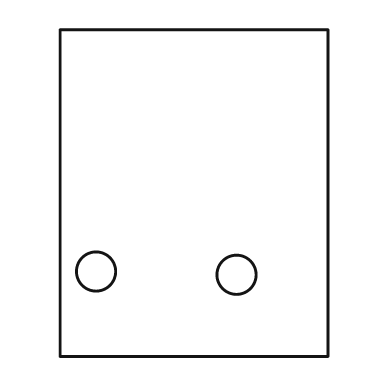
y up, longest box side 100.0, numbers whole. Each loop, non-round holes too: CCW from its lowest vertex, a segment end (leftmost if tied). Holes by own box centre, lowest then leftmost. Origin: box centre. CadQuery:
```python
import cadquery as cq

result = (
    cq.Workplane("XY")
    .moveTo(-41.0, -50.0)
    .lineTo(41.0, -50.0)
    .lineTo(41.0, 50.0)
    .lineTo(-41.0, 50.0)
    .close()
    .moveTo(13.0, -25.0)
    .circle(6.0)
    .moveTo(-30.0, -24.0)
    .circle(6.0)
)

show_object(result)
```